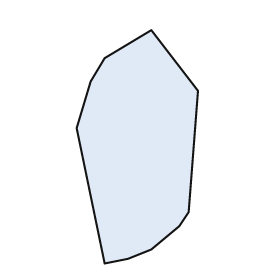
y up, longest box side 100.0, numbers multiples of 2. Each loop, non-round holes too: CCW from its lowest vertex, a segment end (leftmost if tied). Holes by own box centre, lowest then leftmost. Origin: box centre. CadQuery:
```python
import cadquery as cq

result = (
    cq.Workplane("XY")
    .moveTo(-14.0, -50.0)
    .lineTo(-4.0, -48.0)
    .lineTo(6.0, -44.0)
    .lineTo(18.0, -34.0)
    .lineTo(22.0, -28.0)
    .lineTo(26.0, 24.0)
    .lineTo(6.0, 50.0)
    .lineTo(-14.0, 38.0)
    .lineTo(-20.0, 28.0)
    .lineTo(-26.0, 8.0)
    .close()
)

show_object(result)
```